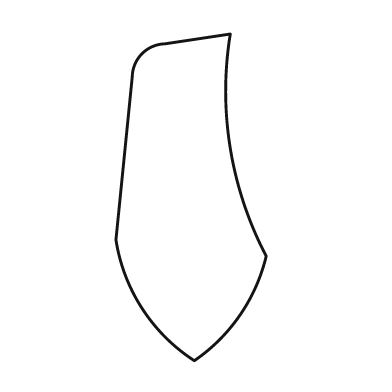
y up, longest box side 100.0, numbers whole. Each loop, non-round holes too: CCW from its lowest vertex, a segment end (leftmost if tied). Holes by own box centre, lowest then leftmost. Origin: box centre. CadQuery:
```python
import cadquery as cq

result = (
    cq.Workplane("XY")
    .moveTo(1.0, -50.0)
    .threePointArc((15.0, -36.0), (23.0, -18.0))
    .threePointArc((12.0, 15.0), (12.0, 50.0))
    .lineTo(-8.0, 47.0)
    .threePointArc((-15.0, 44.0), (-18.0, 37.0))
    .lineTo(-23.0, -13.0)
    .threePointArc((-15.0, -34.0), (1.0, -50.0))
    .close()
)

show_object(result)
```